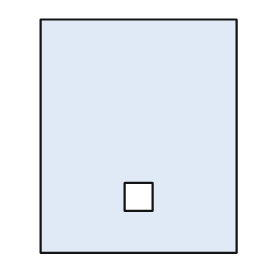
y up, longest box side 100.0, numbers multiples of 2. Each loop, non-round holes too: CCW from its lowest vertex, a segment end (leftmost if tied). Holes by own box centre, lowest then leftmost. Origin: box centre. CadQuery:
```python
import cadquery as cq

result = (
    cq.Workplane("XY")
    .moveTo(-42.0, -50.0)
    .lineTo(42.0, -50.0)
    .lineTo(42.0, 50.0)
    .lineTo(-42.0, 50.0)
    .close()
    .moveTo(-6.0, -32.0)
    .lineTo(6.0, -32.0)
    .lineTo(6.0, -20.0)
    .lineTo(-6.0, -20.0)
    .close()
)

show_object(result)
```